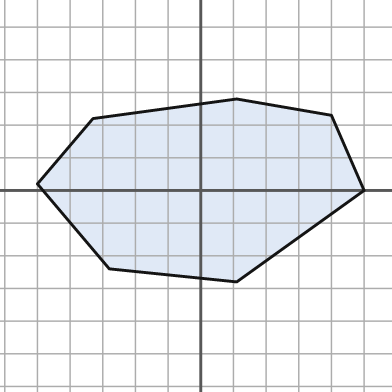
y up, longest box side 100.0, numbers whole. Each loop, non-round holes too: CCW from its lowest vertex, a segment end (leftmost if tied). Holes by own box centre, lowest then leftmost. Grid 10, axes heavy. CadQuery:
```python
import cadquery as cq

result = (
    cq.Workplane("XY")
    .moveTo(11.0, -28.0)
    .lineTo(50.0, 0.0)
    .lineTo(40.0, 23.0)
    .lineTo(11.0, 28.0)
    .lineTo(-33.0, 22.0)
    .lineTo(-50.0, 2.0)
    .lineTo(-28.0, -24.0)
    .close()
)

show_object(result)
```